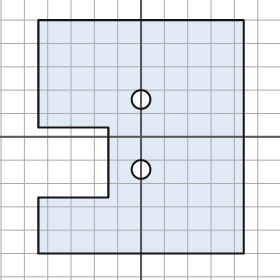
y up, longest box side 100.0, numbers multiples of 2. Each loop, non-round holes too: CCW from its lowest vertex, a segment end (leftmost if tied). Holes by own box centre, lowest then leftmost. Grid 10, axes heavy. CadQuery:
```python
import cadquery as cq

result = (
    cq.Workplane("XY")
    .moveTo(-44.0, -50.0)
    .lineTo(44.0, -50.0)
    .lineTo(44.0, 50.0)
    .lineTo(-44.0, 50.0)
    .lineTo(-44.0, 4.0)
    .lineTo(-14.0, 4.0)
    .lineTo(-14.0, -26.0)
    .lineTo(-44.0, -26.0)
    .close()
    .moveTo(0.0, -14.0)
    .circle(4.0)
    .moveTo(0.0, 16.0)
    .circle(4.0)
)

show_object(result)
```